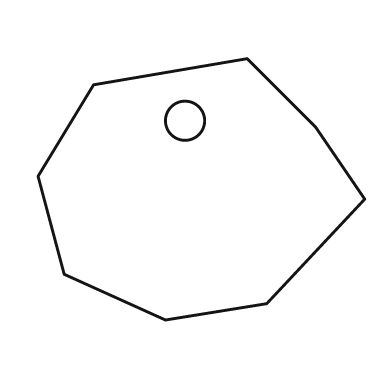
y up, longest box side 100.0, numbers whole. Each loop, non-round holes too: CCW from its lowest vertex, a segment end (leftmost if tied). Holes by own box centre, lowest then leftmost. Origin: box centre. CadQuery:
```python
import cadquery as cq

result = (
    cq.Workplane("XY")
    .moveTo(-11.0, -40.0)
    .lineTo(20.0, -35.0)
    .lineTo(50.0, -3.0)
    .lineTo(35.0, 19.0)
    .lineTo(14.0, 40.0)
    .lineTo(-33.0, 32.0)
    .lineTo(-50.0, 4.0)
    .lineTo(-42.0, -26.0)
    .close()
    .moveTo(-5.0, 21.0)
    .circle(6.0)
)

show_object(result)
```